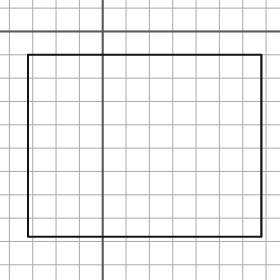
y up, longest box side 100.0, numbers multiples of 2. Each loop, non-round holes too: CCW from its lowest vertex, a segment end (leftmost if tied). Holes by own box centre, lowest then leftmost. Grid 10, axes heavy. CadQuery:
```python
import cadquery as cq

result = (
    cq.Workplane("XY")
    .moveTo(-32.0, -88.0)
    .lineTo(68.0, -88.0)
    .lineTo(68.0, -10.0)
    .lineTo(-32.0, -10.0)
    .close()
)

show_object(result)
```